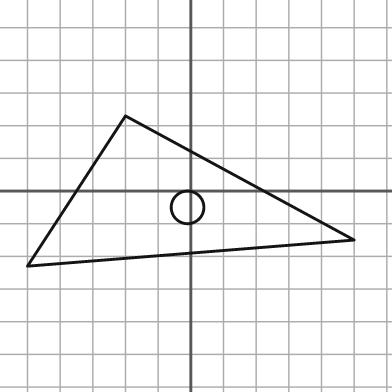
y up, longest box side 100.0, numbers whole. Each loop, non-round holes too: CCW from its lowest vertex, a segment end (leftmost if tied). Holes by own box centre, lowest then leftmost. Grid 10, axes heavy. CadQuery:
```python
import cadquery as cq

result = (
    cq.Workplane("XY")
    .moveTo(-50.0, -23.0)
    .lineTo(50.0, -15.0)
    .lineTo(-20.0, 23.0)
    .close()
    .moveTo(-1.0, -5.0)
    .circle(5.0)
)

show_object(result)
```